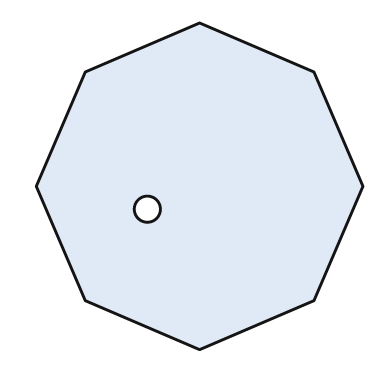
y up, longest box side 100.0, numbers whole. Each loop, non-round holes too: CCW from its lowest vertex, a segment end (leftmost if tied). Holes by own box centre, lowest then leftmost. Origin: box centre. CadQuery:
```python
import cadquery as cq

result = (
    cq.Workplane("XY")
    .moveTo(0.0, -50.0)
    .lineTo(35.0, -35.0)
    .lineTo(50.0, 0.0)
    .lineTo(35.0, 35.0)
    .lineTo(0.0, 50.0)
    .lineTo(-35.0, 35.0)
    .lineTo(-50.0, 0.0)
    .lineTo(-35.0, -35.0)
    .close()
    .moveTo(-16.0, -7.0)
    .circle(4.0)
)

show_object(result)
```